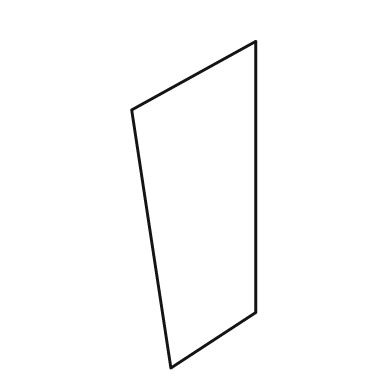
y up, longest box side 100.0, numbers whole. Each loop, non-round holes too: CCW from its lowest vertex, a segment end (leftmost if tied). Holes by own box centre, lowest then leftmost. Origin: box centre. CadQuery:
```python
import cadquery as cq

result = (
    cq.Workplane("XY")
    .moveTo(-7.0, -50.0)
    .lineTo(19.0, -33.0)
    .lineTo(19.0, 50.0)
    .lineTo(-19.0, 29.0)
    .close()
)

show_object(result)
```